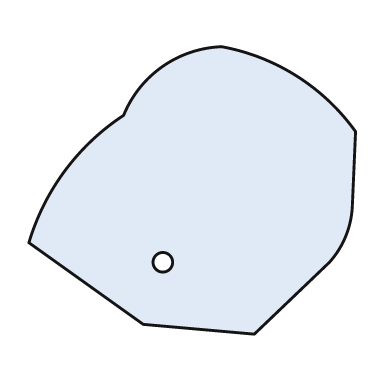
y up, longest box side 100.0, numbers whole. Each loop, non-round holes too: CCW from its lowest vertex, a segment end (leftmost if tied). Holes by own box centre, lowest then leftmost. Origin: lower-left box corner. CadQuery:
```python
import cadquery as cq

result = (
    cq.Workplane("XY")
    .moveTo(69.0, 0.0)
    .lineTo(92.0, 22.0)
    .threePointArc((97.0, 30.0), (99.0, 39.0))
    .lineTo(100.0, 62.0)
    .threePointArc((82.0, 79.0), (59.0, 88.0))
    .threePointArc((41.0, 82.0), (29.0, 67.0))
    .threePointArc((11.0, 50.0), (0.0, 28.0))
    .lineTo(35.0, 3.0)
    .close()
    .moveTo(41.0, 22.0)
    .circle(3.0)
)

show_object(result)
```